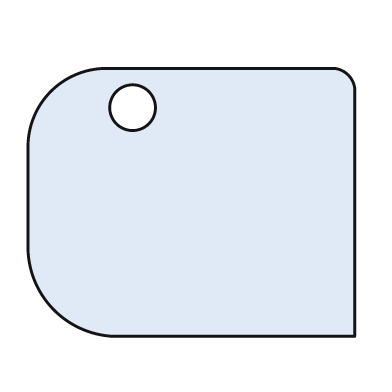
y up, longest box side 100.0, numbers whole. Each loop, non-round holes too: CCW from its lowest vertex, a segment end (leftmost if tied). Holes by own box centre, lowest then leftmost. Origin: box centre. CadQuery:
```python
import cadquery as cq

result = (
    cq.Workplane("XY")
    .moveTo(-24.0, -41.0)
    .lineTo(50.0, -41.0)
    .lineTo(50.0, 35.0)
    .threePointArc((48.0, 39.0), (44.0, 41.0))
    .lineTo(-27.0, 41.0)
    .threePointArc((-43.0, 34.0), (-50.0, 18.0))
    .lineTo(-50.0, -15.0)
    .threePointArc((-42.0, -33.0), (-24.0, -41.0))
    .close()
    .moveTo(-18.0, 29.0)
    .circle(7.0)
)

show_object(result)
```